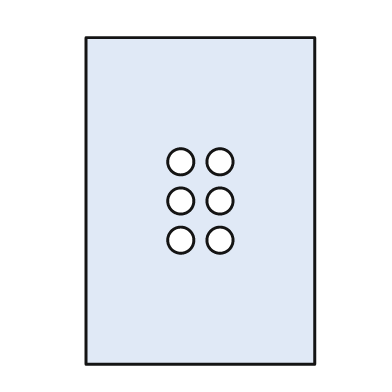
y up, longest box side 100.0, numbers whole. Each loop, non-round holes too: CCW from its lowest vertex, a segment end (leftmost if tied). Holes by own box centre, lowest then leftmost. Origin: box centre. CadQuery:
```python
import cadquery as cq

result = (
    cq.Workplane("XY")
    .moveTo(-35.0, -50.0)
    .lineTo(35.0, -50.0)
    .lineTo(35.0, 50.0)
    .lineTo(-35.0, 50.0)
    .close()
    .moveTo(-6.0, -12.0)
    .circle(4.0)
    .moveTo(6.0, -12.0)
    .circle(4.0)
    .moveTo(-6.0, 0.0)
    .circle(4.0)
    .moveTo(6.0, 0.0)
    .circle(4.0)
    .moveTo(-6.0, 12.0)
    .circle(4.0)
    .moveTo(6.0, 12.0)
    .circle(4.0)
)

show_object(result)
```